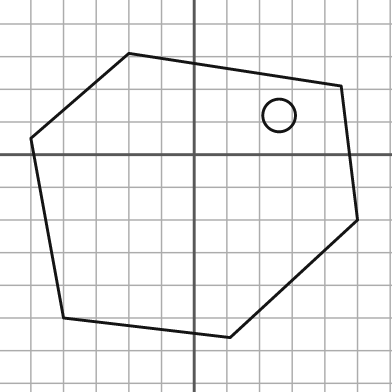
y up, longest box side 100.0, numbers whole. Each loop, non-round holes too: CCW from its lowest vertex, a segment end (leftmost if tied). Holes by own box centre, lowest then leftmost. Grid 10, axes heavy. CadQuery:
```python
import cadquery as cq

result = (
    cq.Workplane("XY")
    .moveTo(11.0, -56.0)
    .lineTo(50.0, -20.0)
    .lineTo(45.0, 21.0)
    .lineTo(-20.0, 31.0)
    .lineTo(-50.0, 5.0)
    .lineTo(-40.0, -50.0)
    .close()
    .moveTo(26.0, 12.0)
    .circle(5.0)
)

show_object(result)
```